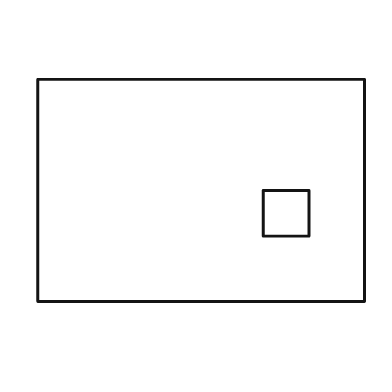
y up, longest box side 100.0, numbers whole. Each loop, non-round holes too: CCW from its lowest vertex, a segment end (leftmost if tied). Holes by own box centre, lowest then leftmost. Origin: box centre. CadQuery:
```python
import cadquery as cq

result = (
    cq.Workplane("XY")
    .moveTo(-50.0, -34.0)
    .lineTo(50.0, -34.0)
    .lineTo(50.0, 34.0)
    .lineTo(-50.0, 34.0)
    .close()
    .moveTo(19.0, -14.0)
    .lineTo(33.0, -14.0)
    .lineTo(33.0, 0.0)
    .lineTo(19.0, 0.0)
    .close()
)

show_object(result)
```